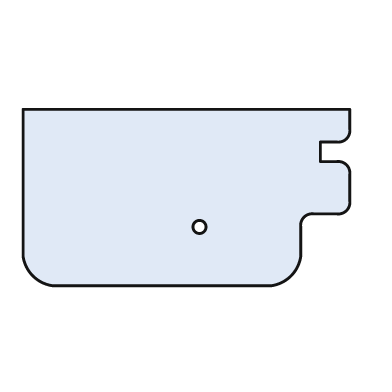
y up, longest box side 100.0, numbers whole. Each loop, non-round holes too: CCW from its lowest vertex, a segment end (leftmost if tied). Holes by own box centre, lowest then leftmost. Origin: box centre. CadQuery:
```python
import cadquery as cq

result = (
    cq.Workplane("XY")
    .moveTo(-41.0, -27.0)
    .lineTo(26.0, -27.0)
    .threePointArc((32.0, -24.0), (35.0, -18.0))
    .lineTo(35.0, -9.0)
    .threePointArc((36.0, -6.0), (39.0, -5.0))
    .lineTo(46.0, -5.0)
    .threePointArc((49.0, -4.0), (50.0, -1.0))
    .lineTo(50.0, 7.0)
    .threePointArc((49.0, 10.0), (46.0, 11.0))
    .lineTo(41.0, 11.0)
    .lineTo(41.0, 17.0)
    .lineTo(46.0, 17.0)
    .threePointArc((49.0, 18.0), (50.0, 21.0))
    .lineTo(50.0, 27.0)
    .lineTo(-50.0, 27.0)
    .lineTo(-50.0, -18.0)
    .threePointArc((-47.0, -24.0), (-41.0, -27.0))
    .close()
    .moveTo(4.0, -9.0)
    .circle(2.0)
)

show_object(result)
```